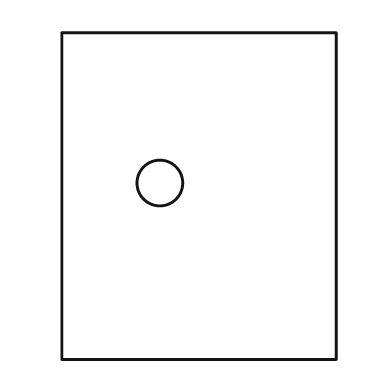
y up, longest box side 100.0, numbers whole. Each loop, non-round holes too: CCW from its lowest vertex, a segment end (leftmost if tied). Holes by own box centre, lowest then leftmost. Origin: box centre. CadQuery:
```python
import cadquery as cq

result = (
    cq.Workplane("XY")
    .moveTo(-42.0, -50.0)
    .lineTo(42.0, -50.0)
    .lineTo(42.0, 50.0)
    .lineTo(-42.0, 50.0)
    .close()
    .moveTo(-12.0, 4.0)
    .circle(7.0)
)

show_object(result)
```